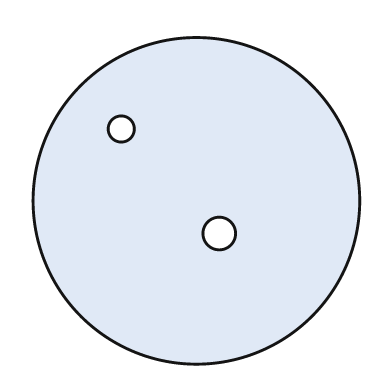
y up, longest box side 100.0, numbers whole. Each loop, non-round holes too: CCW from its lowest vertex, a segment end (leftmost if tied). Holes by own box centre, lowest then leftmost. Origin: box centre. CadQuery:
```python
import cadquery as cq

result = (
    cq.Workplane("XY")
    .moveTo(0.0, 0.0)
    .circle(50.0)
    .moveTo(7.0, -10.0)
    .circle(5.0)
    .moveTo(-23.0, 22.0)
    .circle(4.0)
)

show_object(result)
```